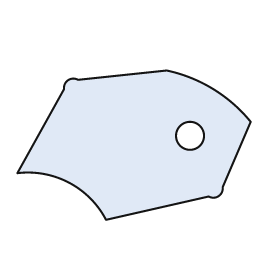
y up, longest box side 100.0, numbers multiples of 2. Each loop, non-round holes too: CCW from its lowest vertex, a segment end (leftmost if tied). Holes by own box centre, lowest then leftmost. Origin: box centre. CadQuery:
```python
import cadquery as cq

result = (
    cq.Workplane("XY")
    .moveTo(-12.0, -32.0)
    .lineTo(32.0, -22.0)
    .threePointArc((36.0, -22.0), (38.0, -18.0))
    .lineTo(50.0, 10.0)
    .threePointArc((34.0, 24.0), (14.0, 32.0))
    .lineTo(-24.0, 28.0)
    .threePointArc((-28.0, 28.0), (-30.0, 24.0))
    .lineTo(-50.0, -12.0)
    .threePointArc((-28.0, -16.0), (-12.0, -32.0))
    .close()
    .moveTo(24.0, 4.0)
    .circle(6.0)
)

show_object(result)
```